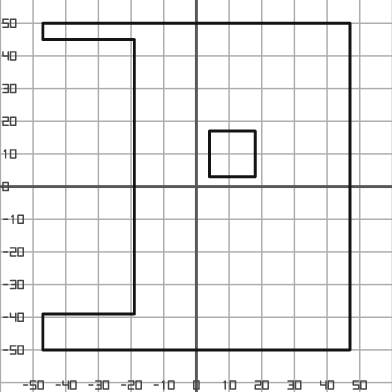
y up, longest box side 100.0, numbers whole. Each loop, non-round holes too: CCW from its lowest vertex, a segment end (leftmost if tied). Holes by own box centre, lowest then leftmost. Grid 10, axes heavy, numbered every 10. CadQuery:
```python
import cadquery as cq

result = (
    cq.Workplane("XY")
    .moveTo(-47.0, -50.0)
    .lineTo(47.0, -50.0)
    .lineTo(47.0, 50.0)
    .lineTo(-47.0, 50.0)
    .lineTo(-47.0, 45.0)
    .lineTo(-19.0, 45.0)
    .lineTo(-19.0, -39.0)
    .lineTo(-47.0, -39.0)
    .close()
    .moveTo(4.0, 3.0)
    .lineTo(18.0, 3.0)
    .lineTo(18.0, 17.0)
    .lineTo(4.0, 17.0)
    .close()
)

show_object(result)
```